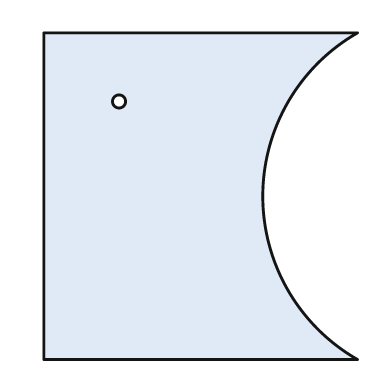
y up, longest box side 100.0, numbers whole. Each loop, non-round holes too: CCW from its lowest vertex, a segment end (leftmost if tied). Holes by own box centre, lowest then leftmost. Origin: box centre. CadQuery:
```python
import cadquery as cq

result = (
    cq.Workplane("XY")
    .moveTo(-48.0, -50.0)
    .lineTo(48.0, -50.0)
    .threePointArc((19.0, 0.0), (48.0, 50.0))
    .lineTo(-48.0, 50.0)
    .close()
    .moveTo(-25.0, 29.0)
    .circle(2.0)
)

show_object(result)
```